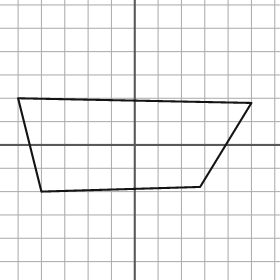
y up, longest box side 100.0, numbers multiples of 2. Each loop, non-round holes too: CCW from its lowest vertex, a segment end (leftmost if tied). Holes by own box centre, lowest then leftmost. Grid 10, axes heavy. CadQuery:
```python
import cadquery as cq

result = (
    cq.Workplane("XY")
    .moveTo(-40.0, -20.0)
    .lineTo(28.0, -18.0)
    .lineTo(50.0, 18.0)
    .lineTo(-50.0, 20.0)
    .close()
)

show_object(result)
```